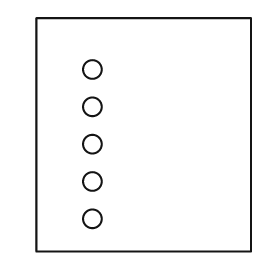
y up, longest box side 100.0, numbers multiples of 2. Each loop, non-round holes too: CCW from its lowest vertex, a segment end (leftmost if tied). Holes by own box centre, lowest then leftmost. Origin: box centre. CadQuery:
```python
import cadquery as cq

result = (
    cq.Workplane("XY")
    .moveTo(-46.0, -50.0)
    .lineTo(46.0, -50.0)
    .lineTo(46.0, 50.0)
    .lineTo(-46.0, 50.0)
    .close()
    .moveTo(-22.0, -36.0)
    .circle(4.0)
    .moveTo(-22.0, -20.0)
    .circle(4.0)
    .moveTo(-22.0, -4.0)
    .circle(4.0)
    .moveTo(-22.0, 12.0)
    .circle(4.0)
    .moveTo(-22.0, 28.0)
    .circle(4.0)
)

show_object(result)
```